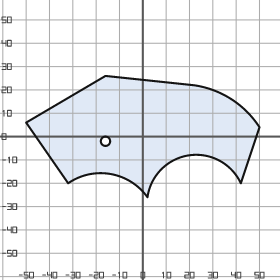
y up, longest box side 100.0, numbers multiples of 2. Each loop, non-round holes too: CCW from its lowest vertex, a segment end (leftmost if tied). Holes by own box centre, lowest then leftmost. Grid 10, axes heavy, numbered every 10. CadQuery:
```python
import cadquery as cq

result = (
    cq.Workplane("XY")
    .moveTo(2.0, -26.0)
    .threePointArc((20.0, -8.0), (42.0, -20.0))
    .lineTo(50.0, 4.0)
    .threePointArc((38.0, 16.0), (22.0, 22.0))
    .lineTo(-16.0, 26.0)
    .lineTo(-50.0, 6.0)
    .lineTo(-32.0, -20.0)
    .threePointArc((-14.0, -16.0), (2.0, -26.0))
    .close()
    .moveTo(-16.0, -2.0)
    .circle(2.0)
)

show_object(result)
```